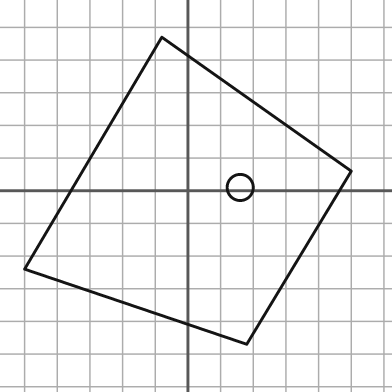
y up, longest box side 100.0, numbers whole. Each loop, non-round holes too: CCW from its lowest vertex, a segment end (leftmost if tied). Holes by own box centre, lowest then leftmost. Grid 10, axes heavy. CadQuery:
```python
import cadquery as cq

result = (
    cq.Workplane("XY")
    .moveTo(18.0, -47.0)
    .lineTo(50.0, 6.0)
    .lineTo(-8.0, 47.0)
    .lineTo(-50.0, -24.0)
    .close()
    .moveTo(16.0, 1.0)
    .circle(4.0)
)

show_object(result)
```